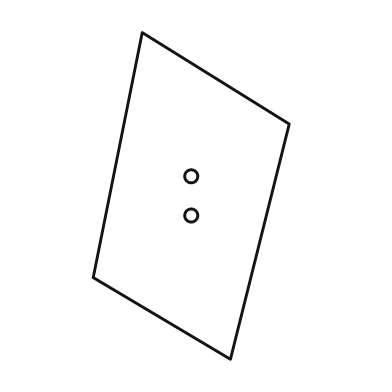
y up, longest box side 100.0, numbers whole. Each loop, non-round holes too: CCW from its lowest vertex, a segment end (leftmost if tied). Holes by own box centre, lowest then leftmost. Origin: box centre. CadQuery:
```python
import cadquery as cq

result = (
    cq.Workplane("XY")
    .moveTo(12.0, -50.0)
    .lineTo(30.0, 22.0)
    .lineTo(-15.0, 50.0)
    .lineTo(-30.0, -25.0)
    .close()
    .moveTo(0.0, -6.0)
    .circle(2.0)
    .moveTo(0.0, 6.0)
    .circle(2.0)
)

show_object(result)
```